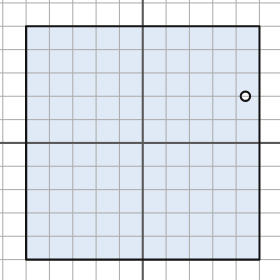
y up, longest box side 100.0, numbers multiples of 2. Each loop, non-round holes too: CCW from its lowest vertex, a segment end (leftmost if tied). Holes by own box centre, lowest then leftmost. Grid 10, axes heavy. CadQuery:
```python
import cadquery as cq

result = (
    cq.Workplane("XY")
    .moveTo(-50.0, -50.0)
    .lineTo(50.0, -50.0)
    .lineTo(50.0, 50.0)
    .lineTo(-50.0, 50.0)
    .close()
    .moveTo(44.0, 20.0)
    .circle(2.0)
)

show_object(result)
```